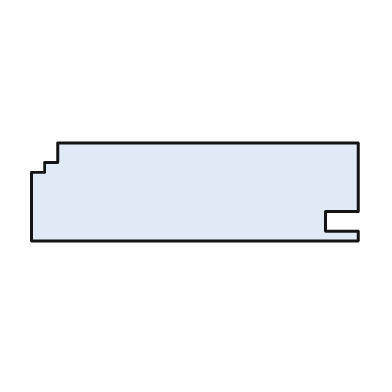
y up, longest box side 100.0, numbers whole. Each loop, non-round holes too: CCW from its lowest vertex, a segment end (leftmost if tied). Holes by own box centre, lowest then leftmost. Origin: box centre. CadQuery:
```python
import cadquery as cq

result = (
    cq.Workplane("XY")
    .moveTo(-50.0, -15.0)
    .lineTo(50.0, -15.0)
    .lineTo(50.0, -12.0)
    .lineTo(40.0, -12.0)
    .lineTo(40.0, -6.0)
    .lineTo(50.0, -6.0)
    .lineTo(50.0, 15.0)
    .lineTo(-42.0, 15.0)
    .lineTo(-42.0, 9.0)
    .lineTo(-46.0, 9.0)
    .lineTo(-46.0, 6.0)
    .lineTo(-50.0, 6.0)
    .close()
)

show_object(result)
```